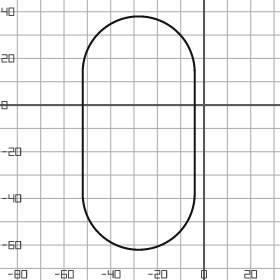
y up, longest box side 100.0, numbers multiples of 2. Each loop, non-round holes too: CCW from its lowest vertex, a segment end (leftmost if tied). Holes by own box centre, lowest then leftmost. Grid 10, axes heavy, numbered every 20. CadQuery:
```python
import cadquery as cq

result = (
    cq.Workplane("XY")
    .moveTo(-52.0, -38.0)
    .threePointArc((-28.0, -62.0), (-4.0, -38.0))
    .lineTo(-4.0, 14.0)
    .threePointArc((-28.0, 38.0), (-52.0, 14.0))
    .close()
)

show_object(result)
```